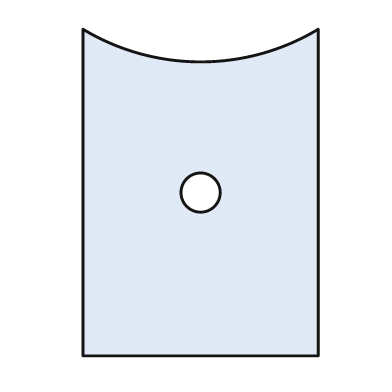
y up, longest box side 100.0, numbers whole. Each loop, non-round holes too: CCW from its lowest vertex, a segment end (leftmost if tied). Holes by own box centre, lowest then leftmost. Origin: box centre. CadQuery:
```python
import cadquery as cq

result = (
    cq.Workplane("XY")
    .moveTo(-36.0, -50.0)
    .lineTo(36.0, -50.0)
    .lineTo(36.0, 50.0)
    .threePointArc((0.0, 40.0), (-36.0, 50.0))
    .close()
    .moveTo(0.0, 0.0)
    .circle(6.0)
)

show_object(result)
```